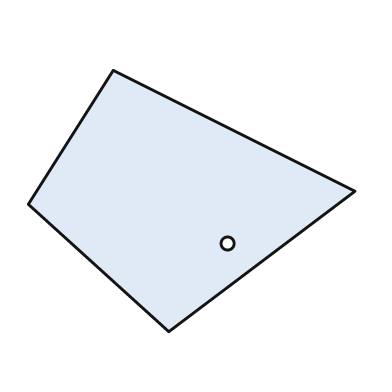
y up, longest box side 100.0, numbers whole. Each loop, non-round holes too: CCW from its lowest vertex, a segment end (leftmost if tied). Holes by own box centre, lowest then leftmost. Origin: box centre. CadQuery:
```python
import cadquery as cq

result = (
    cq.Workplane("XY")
    .moveTo(-7.0, -40.0)
    .lineTo(50.0, 3.0)
    .lineTo(-24.0, 40.0)
    .lineTo(-50.0, -1.0)
    .close()
    .moveTo(11.0, -13.0)
    .circle(2.0)
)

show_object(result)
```